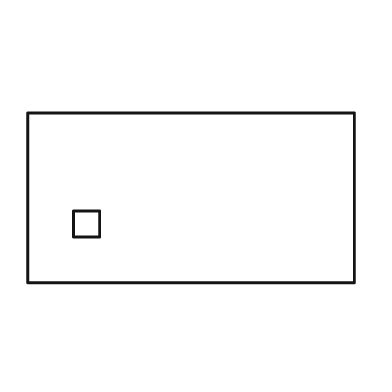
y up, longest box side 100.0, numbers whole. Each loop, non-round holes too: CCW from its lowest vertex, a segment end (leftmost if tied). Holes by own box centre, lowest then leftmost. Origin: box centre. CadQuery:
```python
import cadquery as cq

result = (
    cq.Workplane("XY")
    .moveTo(-50.0, -26.0)
    .lineTo(50.0, -26.0)
    .lineTo(50.0, 26.0)
    .lineTo(-50.0, 26.0)
    .close()
    .moveTo(-36.0, -12.0)
    .lineTo(-28.0, -12.0)
    .lineTo(-28.0, -4.0)
    .lineTo(-36.0, -4.0)
    .close()
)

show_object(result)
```